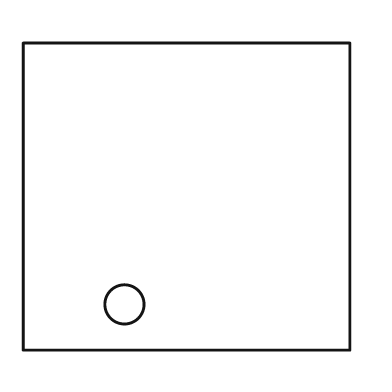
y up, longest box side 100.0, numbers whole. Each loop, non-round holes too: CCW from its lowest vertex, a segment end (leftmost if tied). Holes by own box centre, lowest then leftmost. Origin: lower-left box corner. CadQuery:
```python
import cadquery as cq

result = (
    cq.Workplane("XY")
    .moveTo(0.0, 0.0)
    .lineTo(100.0, 0.0)
    .lineTo(100.0, 94.0)
    .lineTo(0.0, 94.0)
    .close()
    .moveTo(31.0, 14.0)
    .circle(6.0)
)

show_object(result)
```